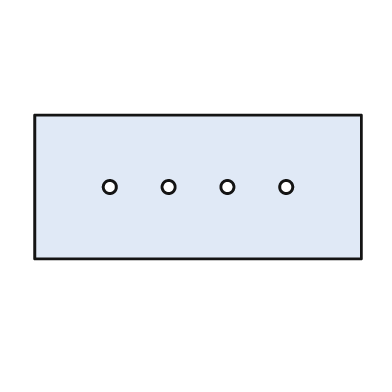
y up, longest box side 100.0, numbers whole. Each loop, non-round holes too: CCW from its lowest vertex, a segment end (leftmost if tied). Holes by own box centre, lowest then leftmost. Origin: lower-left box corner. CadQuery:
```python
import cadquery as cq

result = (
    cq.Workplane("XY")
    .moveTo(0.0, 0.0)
    .lineTo(100.0, 0.0)
    .lineTo(100.0, 44.0)
    .lineTo(0.0, 44.0)
    .close()
    .moveTo(23.0, 22.0)
    .circle(2.0)
    .moveTo(41.0, 22.0)
    .circle(2.0)
    .moveTo(59.0, 22.0)
    .circle(2.0)
    .moveTo(77.0, 22.0)
    .circle(2.0)
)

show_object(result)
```